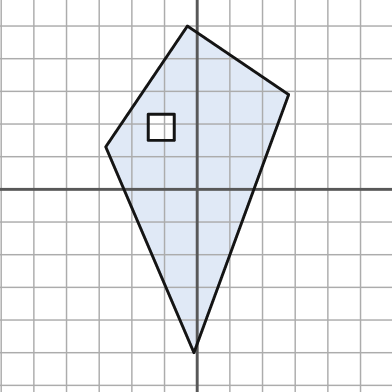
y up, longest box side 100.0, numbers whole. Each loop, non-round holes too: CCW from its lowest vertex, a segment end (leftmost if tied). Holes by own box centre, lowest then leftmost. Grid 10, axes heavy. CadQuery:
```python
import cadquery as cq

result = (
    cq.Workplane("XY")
    .moveTo(-1.0, -50.0)
    .lineTo(28.0, 29.0)
    .lineTo(-3.0, 50.0)
    .lineTo(-28.0, 13.0)
    .close()
    .moveTo(-15.0, 15.0)
    .lineTo(-7.0, 15.0)
    .lineTo(-7.0, 23.0)
    .lineTo(-15.0, 23.0)
    .close()
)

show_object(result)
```